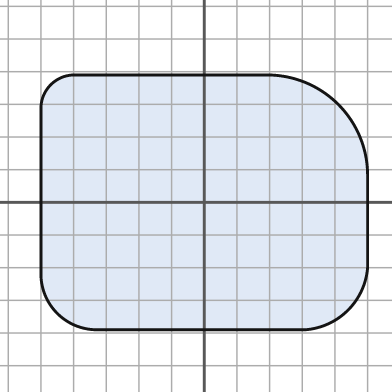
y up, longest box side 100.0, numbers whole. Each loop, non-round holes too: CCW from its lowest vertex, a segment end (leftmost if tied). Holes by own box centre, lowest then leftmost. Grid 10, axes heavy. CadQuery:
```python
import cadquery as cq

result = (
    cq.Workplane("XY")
    .moveTo(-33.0, -39.0)
    .lineTo(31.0, -39.0)
    .threePointArc((44.0, -33.0), (50.0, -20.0))
    .lineTo(50.0, 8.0)
    .threePointArc((41.0, 30.0), (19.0, 39.0))
    .lineTo(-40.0, 39.0)
    .threePointArc((-47.0, 36.0), (-50.0, 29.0))
    .lineTo(-50.0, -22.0)
    .threePointArc((-45.0, -34.0), (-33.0, -39.0))
    .close()
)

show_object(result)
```